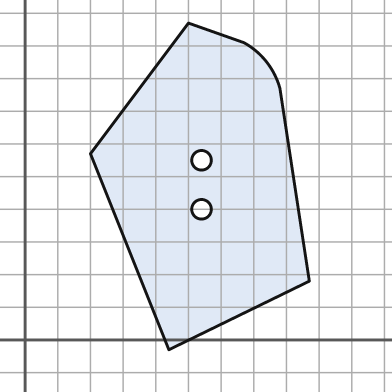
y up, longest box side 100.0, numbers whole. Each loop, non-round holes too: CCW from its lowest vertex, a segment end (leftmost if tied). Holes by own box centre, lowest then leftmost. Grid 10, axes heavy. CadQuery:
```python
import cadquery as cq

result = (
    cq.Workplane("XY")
    .moveTo(44.0, -3.0)
    .lineTo(87.0, 18.0)
    .lineTo(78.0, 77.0)
    .threePointArc((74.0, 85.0), (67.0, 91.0))
    .lineTo(50.0, 97.0)
    .lineTo(20.0, 57.0)
    .close()
    .moveTo(54.0, 40.0)
    .circle(3.0)
    .moveTo(54.0, 55.0)
    .circle(3.0)
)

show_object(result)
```